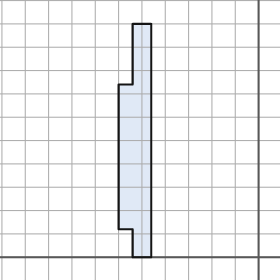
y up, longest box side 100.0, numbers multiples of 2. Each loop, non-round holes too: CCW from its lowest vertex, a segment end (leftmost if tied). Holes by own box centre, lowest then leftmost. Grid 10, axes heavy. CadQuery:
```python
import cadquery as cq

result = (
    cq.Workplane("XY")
    .moveTo(-54.0, 0.0)
    .lineTo(-46.0, 0.0)
    .lineTo(-46.0, 100.0)
    .lineTo(-54.0, 100.0)
    .lineTo(-54.0, 74.0)
    .lineTo(-60.0, 74.0)
    .lineTo(-60.0, 12.0)
    .lineTo(-54.0, 12.0)
    .close()
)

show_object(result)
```